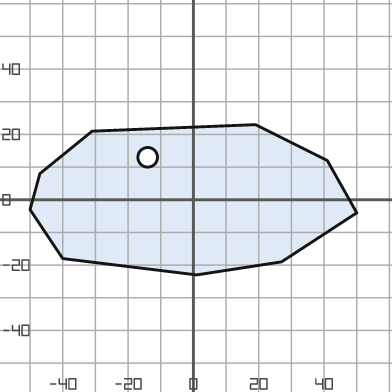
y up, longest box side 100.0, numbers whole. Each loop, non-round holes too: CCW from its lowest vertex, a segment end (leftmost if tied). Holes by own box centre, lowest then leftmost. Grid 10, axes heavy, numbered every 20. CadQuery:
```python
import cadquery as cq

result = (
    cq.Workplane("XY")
    .moveTo(1.0, -23.0)
    .lineTo(27.0, -19.0)
    .lineTo(50.0, -4.0)
    .lineTo(41.0, 12.0)
    .lineTo(19.0, 23.0)
    .lineTo(-31.0, 21.0)
    .lineTo(-47.0, 8.0)
    .lineTo(-50.0, -3.0)
    .lineTo(-40.0, -18.0)
    .close()
    .moveTo(-14.0, 13.0)
    .circle(3.0)
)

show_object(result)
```